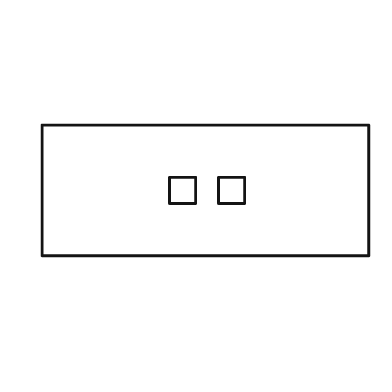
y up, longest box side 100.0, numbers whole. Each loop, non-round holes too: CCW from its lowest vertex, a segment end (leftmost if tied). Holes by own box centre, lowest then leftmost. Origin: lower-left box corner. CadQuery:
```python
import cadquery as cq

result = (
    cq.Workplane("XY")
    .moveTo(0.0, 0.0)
    .lineTo(100.0, 0.0)
    .lineTo(100.0, 40.0)
    .lineTo(0.0, 40.0)
    .close()
    .moveTo(39.0, 16.0)
    .lineTo(47.0, 16.0)
    .lineTo(47.0, 24.0)
    .lineTo(39.0, 24.0)
    .close()
    .moveTo(54.0, 16.0)
    .lineTo(62.0, 16.0)
    .lineTo(62.0, 24.0)
    .lineTo(54.0, 24.0)
    .close()
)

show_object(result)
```